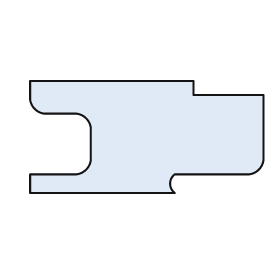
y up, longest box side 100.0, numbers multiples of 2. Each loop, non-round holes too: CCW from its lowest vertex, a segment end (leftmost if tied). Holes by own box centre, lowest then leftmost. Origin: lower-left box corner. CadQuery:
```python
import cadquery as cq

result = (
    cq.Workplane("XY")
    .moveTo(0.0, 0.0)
    .lineTo(62.0, 0.0)
    .threePointArc((60.0, 4.0), (62.0, 8.0))
    .lineTo(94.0, 8.0)
    .threePointArc((98.0, 10.0), (100.0, 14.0))
    .lineTo(100.0, 42.0)
    .lineTo(70.0, 42.0)
    .lineTo(70.0, 48.0)
    .lineTo(0.0, 48.0)
    .lineTo(0.0, 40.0)
    .threePointArc((2.0, 36.0), (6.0, 34.0))
    .lineTo(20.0, 34.0)
    .threePointArc((24.0, 32.0), (26.0, 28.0))
    .lineTo(26.0, 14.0)
    .threePointArc((24.0, 10.0), (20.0, 8.0))
    .lineTo(0.0, 8.0)
    .close()
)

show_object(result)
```